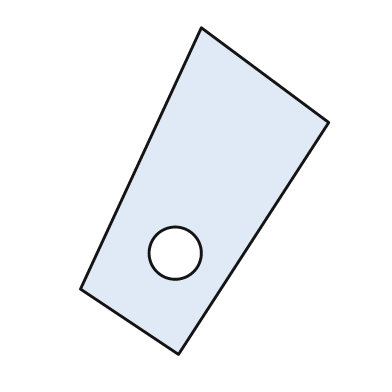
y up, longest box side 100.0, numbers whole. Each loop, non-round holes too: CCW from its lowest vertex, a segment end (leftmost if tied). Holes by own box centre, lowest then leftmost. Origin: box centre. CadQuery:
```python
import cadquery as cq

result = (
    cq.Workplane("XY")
    .moveTo(-8.0, -50.0)
    .lineTo(38.0, 21.0)
    .lineTo(-1.0, 50.0)
    .lineTo(-38.0, -30.0)
    .close()
    .moveTo(-9.0, -19.0)
    .circle(8.0)
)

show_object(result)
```